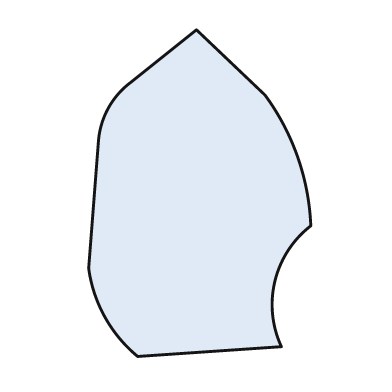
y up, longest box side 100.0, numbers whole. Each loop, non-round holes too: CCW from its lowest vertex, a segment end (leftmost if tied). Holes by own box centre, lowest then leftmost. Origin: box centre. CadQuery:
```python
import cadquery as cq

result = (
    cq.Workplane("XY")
    .moveTo(-19.0, -50.0)
    .lineTo(25.0, -47.0)
    .threePointArc((23.0, -27.0), (34.0, -10.0))
    .threePointArc((30.0, 11.0), (20.0, 30.0))
    .lineTo(-1.0, 50.0)
    .lineTo(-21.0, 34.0)
    .threePointArc((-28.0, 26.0), (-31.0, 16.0))
    .lineTo(-34.0, -23.0)
    .threePointArc((-29.0, -38.0), (-19.0, -50.0))
    .close()
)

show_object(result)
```